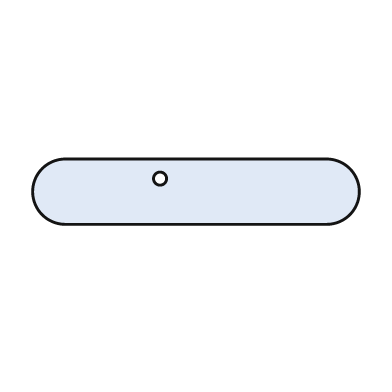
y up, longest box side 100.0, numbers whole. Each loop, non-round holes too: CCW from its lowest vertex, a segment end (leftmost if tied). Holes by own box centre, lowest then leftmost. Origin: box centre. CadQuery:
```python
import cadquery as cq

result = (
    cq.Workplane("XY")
    .moveTo(-40.0, -10.0)
    .lineTo(40.0, -10.0)
    .threePointArc((50.0, 0.0), (40.0, 10.0))
    .lineTo(-40.0, 10.0)
    .threePointArc((-50.0, 0.0), (-40.0, -10.0))
    .close()
    .moveTo(-11.0, 4.0)
    .circle(2.0)
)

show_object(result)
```